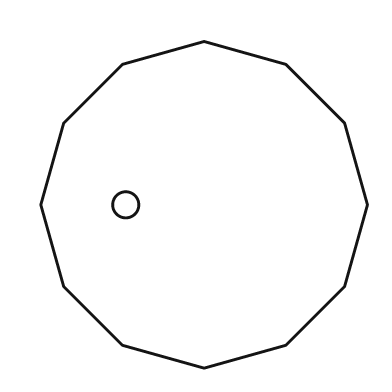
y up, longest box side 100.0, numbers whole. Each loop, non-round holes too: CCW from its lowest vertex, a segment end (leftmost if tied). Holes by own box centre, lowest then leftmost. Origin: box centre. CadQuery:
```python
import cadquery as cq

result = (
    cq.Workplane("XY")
    .moveTo(0.0, -50.0)
    .lineTo(25.0, -43.0)
    .lineTo(43.0, -25.0)
    .lineTo(50.0, 0.0)
    .lineTo(43.0, 25.0)
    .lineTo(25.0, 43.0)
    .lineTo(0.0, 50.0)
    .lineTo(-25.0, 43.0)
    .lineTo(-43.0, 25.0)
    .lineTo(-50.0, 0.0)
    .lineTo(-43.0, -25.0)
    .lineTo(-25.0, -43.0)
    .close()
    .moveTo(-24.0, 0.0)
    .circle(4.0)
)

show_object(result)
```